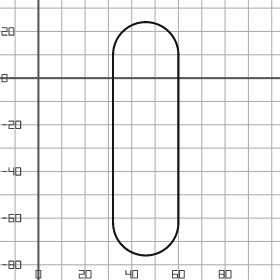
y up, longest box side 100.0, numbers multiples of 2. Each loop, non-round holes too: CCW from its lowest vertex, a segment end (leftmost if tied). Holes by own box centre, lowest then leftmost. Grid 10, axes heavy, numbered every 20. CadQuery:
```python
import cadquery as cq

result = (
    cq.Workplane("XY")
    .moveTo(32.0, -62.0)
    .threePointArc((46.0, -76.0), (60.0, -62.0))
    .lineTo(60.0, 10.0)
    .threePointArc((46.0, 24.0), (32.0, 10.0))
    .close()
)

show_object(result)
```